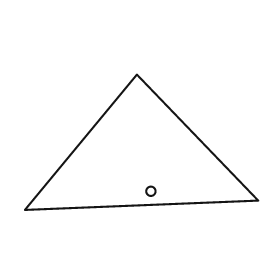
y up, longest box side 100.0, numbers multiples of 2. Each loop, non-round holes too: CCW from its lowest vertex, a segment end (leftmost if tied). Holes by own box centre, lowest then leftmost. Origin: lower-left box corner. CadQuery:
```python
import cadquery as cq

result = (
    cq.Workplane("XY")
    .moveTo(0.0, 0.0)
    .lineTo(100.0, 4.0)
    .lineTo(48.0, 58.0)
    .close()
    .moveTo(54.0, 8.0)
    .circle(2.0)
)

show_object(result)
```